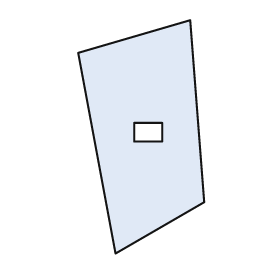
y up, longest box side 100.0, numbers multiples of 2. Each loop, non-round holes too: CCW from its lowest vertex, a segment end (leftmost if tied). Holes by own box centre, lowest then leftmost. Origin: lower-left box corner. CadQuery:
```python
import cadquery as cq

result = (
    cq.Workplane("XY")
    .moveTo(16.0, 0.0)
    .lineTo(54.0, 22.0)
    .lineTo(48.0, 100.0)
    .lineTo(0.0, 86.0)
    .close()
    .moveTo(24.0, 48.0)
    .lineTo(36.0, 48.0)
    .lineTo(36.0, 56.0)
    .lineTo(24.0, 56.0)
    .close()
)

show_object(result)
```